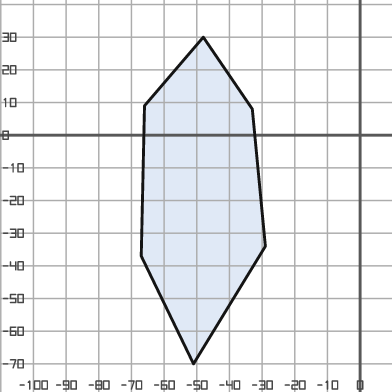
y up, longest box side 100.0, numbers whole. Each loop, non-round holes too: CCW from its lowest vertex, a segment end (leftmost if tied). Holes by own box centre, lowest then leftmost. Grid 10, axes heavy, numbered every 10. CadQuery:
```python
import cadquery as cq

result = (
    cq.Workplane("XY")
    .moveTo(-51.0, -70.0)
    .lineTo(-29.0, -34.0)
    .lineTo(-33.0, 8.0)
    .lineTo(-48.0, 30.0)
    .lineTo(-66.0, 9.0)
    .lineTo(-67.0, -37.0)
    .close()
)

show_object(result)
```